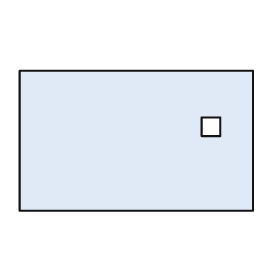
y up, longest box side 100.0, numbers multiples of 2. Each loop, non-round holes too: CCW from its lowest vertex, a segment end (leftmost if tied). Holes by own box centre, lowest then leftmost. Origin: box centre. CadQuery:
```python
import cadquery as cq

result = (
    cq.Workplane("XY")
    .moveTo(-50.0, -30.0)
    .lineTo(50.0, -30.0)
    .lineTo(50.0, 30.0)
    .lineTo(-50.0, 30.0)
    .close()
    .moveTo(28.0, 2.0)
    .lineTo(36.0, 2.0)
    .lineTo(36.0, 10.0)
    .lineTo(28.0, 10.0)
    .close()
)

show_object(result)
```